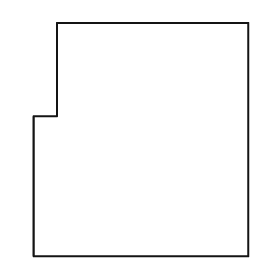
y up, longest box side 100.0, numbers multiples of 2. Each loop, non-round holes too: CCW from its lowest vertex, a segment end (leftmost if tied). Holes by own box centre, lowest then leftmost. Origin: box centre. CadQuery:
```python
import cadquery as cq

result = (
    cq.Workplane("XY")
    .moveTo(-46.0, -50.0)
    .lineTo(46.0, -50.0)
    .lineTo(46.0, 50.0)
    .lineTo(-36.0, 50.0)
    .lineTo(-36.0, 10.0)
    .lineTo(-46.0, 10.0)
    .close()
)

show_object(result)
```